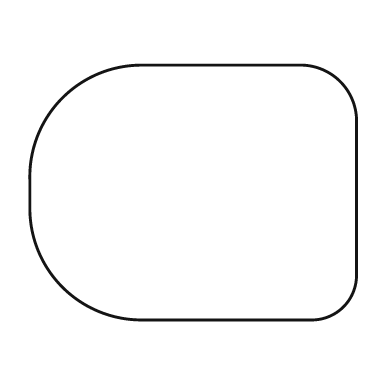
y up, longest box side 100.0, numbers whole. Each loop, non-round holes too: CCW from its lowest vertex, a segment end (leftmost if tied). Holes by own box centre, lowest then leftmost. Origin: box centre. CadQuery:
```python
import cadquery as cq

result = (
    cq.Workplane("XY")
    .moveTo(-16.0, -39.0)
    .lineTo(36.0, -39.0)
    .threePointArc((46.0, -35.0), (50.0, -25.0))
    .lineTo(50.0, 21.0)
    .threePointArc((45.0, 34.0), (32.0, 39.0))
    .lineTo(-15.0, 39.0)
    .threePointArc((-40.0, 29.0), (-50.0, 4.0))
    .lineTo(-50.0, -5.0)
    .threePointArc((-40.0, -29.0), (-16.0, -39.0))
    .close()
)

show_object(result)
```